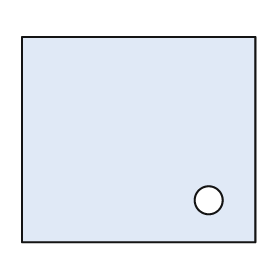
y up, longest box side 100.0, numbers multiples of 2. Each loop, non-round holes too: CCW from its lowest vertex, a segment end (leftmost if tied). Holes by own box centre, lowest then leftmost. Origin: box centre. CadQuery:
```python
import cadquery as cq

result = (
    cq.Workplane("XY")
    .moveTo(-50.0, -44.0)
    .lineTo(50.0, -44.0)
    .lineTo(50.0, 44.0)
    .lineTo(-50.0, 44.0)
    .close()
    .moveTo(30.0, -26.0)
    .circle(6.0)
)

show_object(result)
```